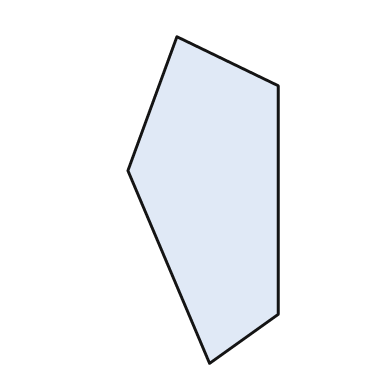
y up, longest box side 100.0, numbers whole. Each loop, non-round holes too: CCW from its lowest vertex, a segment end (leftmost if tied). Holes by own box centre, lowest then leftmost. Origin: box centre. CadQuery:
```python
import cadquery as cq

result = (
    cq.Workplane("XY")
    .moveTo(2.0, -50.0)
    .lineTo(23.0, -35.0)
    .lineTo(23.0, 35.0)
    .lineTo(-8.0, 50.0)
    .lineTo(-23.0, 9.0)
    .close()
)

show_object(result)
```